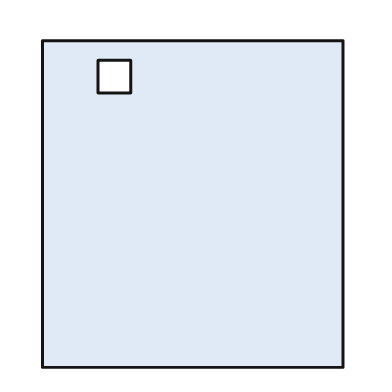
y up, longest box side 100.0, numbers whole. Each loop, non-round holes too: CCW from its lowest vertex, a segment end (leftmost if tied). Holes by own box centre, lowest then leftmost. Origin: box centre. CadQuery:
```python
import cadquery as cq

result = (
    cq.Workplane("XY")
    .moveTo(-46.0, -50.0)
    .lineTo(46.0, -50.0)
    .lineTo(46.0, 50.0)
    .lineTo(-46.0, 50.0)
    .close()
    .moveTo(-29.0, 34.0)
    .lineTo(-19.0, 34.0)
    .lineTo(-19.0, 44.0)
    .lineTo(-29.0, 44.0)
    .close()
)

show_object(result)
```